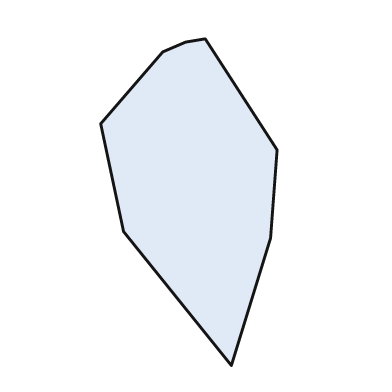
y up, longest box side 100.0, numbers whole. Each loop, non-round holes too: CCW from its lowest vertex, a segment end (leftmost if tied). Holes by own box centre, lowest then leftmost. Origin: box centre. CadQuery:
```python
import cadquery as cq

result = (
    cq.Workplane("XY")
    .moveTo(13.0, -50.0)
    .lineTo(25.0, -11.0)
    .lineTo(27.0, 16.0)
    .lineTo(5.0, 50.0)
    .lineTo(-1.0, 49.0)
    .lineTo(-8.0, 46.0)
    .lineTo(-27.0, 24.0)
    .lineTo(-20.0, -9.0)
    .close()
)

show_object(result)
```